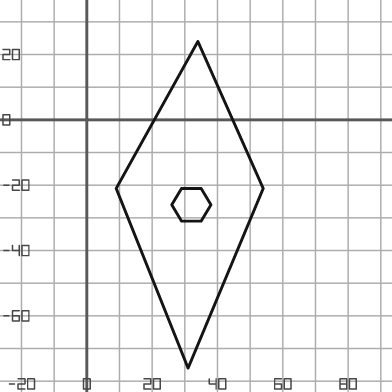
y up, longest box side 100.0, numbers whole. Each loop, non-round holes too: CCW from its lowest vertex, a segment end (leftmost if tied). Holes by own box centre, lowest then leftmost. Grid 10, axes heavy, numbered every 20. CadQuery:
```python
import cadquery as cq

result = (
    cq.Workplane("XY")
    .moveTo(31.0, -76.0)
    .lineTo(54.0, -21.0)
    .lineTo(34.0, 24.0)
    .lineTo(9.0, -21.0)
    .close()
    .moveTo(29.0, -31.0)
    .lineTo(35.0, -31.0)
    .lineTo(38.0, -26.0)
    .lineTo(35.0, -21.0)
    .lineTo(29.0, -21.0)
    .lineTo(26.0, -26.0)
    .close()
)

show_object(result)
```